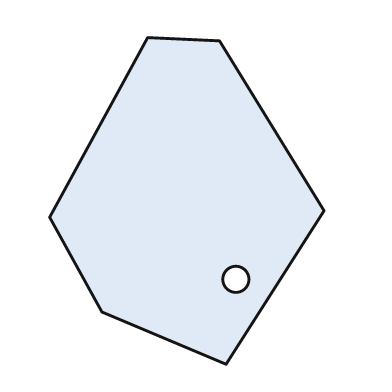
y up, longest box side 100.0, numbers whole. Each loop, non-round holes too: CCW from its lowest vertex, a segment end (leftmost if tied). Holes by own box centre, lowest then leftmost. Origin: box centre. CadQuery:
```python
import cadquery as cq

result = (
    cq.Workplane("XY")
    .moveTo(12.0, -50.0)
    .lineTo(42.0, -3.0)
    .lineTo(10.0, 49.0)
    .lineTo(-12.0, 50.0)
    .lineTo(-42.0, -5.0)
    .lineTo(-26.0, -34.0)
    .close()
    .moveTo(15.0, -24.0)
    .circle(4.0)
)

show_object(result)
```